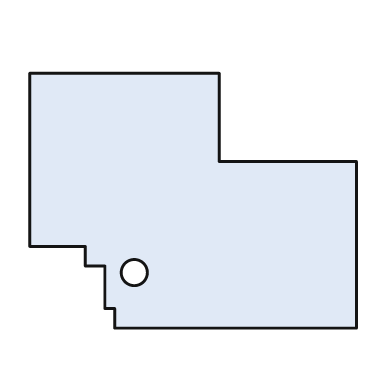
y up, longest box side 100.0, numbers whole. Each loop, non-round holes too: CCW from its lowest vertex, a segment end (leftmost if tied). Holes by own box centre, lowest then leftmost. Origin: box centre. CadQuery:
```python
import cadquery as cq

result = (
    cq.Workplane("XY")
    .moveTo(-24.0, -39.0)
    .lineTo(50.0, -39.0)
    .lineTo(50.0, 12.0)
    .lineTo(8.0, 12.0)
    .lineTo(8.0, 39.0)
    .lineTo(-50.0, 39.0)
    .lineTo(-50.0, -14.0)
    .lineTo(-33.0, -14.0)
    .lineTo(-33.0, -20.0)
    .lineTo(-27.0, -20.0)
    .lineTo(-27.0, -33.0)
    .lineTo(-24.0, -33.0)
    .close()
    .moveTo(-18.0, -22.0)
    .circle(4.0)
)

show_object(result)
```